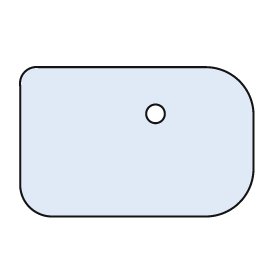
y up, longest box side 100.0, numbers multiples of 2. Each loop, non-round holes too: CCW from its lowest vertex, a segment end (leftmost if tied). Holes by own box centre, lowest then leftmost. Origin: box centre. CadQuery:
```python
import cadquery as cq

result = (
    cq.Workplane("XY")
    .moveTo(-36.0, -32.0)
    .lineTo(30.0, -32.0)
    .threePointArc((44.0, -26.0), (50.0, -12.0))
    .lineTo(50.0, 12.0)
    .threePointArc((44.0, 26.0), (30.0, 32.0))
    .lineTo(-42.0, 32.0)
    .threePointArc((-48.0, 30.0), (-50.0, 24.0))
    .lineTo(-50.0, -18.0)
    .threePointArc((-46.0, -28.0), (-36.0, -32.0))
    .close()
    .moveTo(8.0, 12.0)
    .circle(4.0)
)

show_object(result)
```